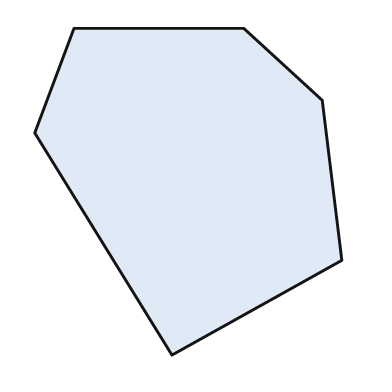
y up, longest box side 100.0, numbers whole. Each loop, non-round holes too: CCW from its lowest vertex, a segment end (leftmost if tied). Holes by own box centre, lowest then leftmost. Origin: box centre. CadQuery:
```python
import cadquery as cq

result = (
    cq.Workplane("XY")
    .moveTo(-5.0, -50.0)
    .lineTo(47.0, -21.0)
    .lineTo(41.0, 28.0)
    .lineTo(17.0, 50.0)
    .lineTo(-35.0, 50.0)
    .lineTo(-47.0, 18.0)
    .close()
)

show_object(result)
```